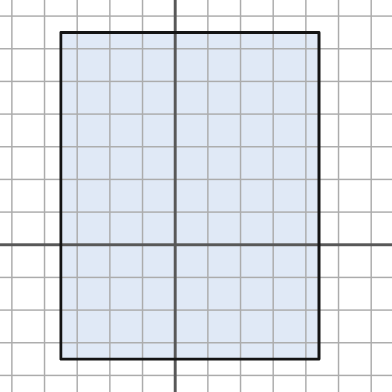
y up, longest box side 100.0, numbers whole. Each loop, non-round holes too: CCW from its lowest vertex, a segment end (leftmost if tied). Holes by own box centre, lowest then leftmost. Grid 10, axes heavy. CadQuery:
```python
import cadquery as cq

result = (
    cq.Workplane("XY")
    .moveTo(-35.0, -35.0)
    .lineTo(44.0, -35.0)
    .lineTo(44.0, 65.0)
    .lineTo(-35.0, 65.0)
    .close()
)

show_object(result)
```